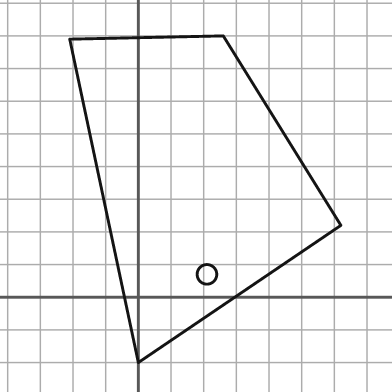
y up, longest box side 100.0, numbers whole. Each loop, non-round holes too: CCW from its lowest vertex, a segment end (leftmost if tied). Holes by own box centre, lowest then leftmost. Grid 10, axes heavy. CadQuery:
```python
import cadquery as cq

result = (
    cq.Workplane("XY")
    .moveTo(0.0, -20.0)
    .lineTo(62.0, 22.0)
    .lineTo(26.0, 80.0)
    .lineTo(-21.0, 79.0)
    .close()
    .moveTo(21.0, 7.0)
    .circle(3.0)
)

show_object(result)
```